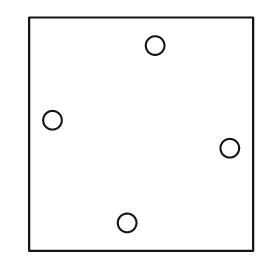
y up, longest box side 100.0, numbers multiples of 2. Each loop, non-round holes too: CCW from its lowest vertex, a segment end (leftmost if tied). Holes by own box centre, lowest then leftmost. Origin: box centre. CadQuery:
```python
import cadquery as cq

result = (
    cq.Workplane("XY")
    .moveTo(-48.0, -50.0)
    .lineTo(48.0, -50.0)
    .lineTo(48.0, 50.0)
    .lineTo(-48.0, 50.0)
    .close()
    .moveTo(-6.0, -38.0)
    .circle(4.0)
    .moveTo(38.0, -6.0)
    .circle(4.0)
    .moveTo(-38.0, 6.0)
    .circle(4.0)
    .moveTo(6.0, 38.0)
    .circle(4.0)
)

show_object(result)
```